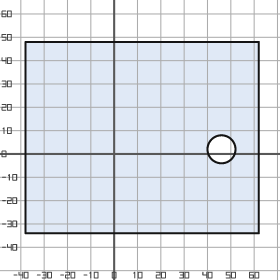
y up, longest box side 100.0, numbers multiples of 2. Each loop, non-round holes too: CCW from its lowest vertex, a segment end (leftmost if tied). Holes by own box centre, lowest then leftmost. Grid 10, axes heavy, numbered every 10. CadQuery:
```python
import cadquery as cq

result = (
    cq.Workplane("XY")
    .moveTo(-38.0, -34.0)
    .lineTo(62.0, -34.0)
    .lineTo(62.0, 48.0)
    .lineTo(-38.0, 48.0)
    .close()
    .moveTo(46.0, 2.0)
    .circle(6.0)
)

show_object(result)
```